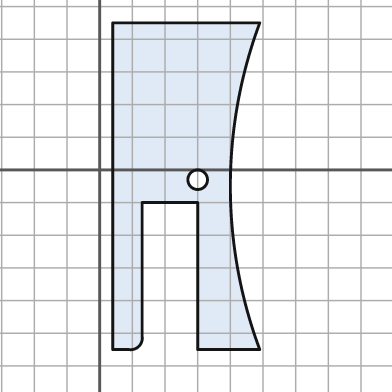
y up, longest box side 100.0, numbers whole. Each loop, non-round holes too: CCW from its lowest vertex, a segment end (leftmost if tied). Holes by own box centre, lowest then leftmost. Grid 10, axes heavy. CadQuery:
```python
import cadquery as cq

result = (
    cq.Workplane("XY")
    .moveTo(4.0, -55.0)
    .lineTo(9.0, -55.0)
    .threePointArc((12.0, -54.0), (13.0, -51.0))
    .lineTo(13.0, -10.0)
    .lineTo(30.0, -10.0)
    .lineTo(30.0, -55.0)
    .lineTo(49.0, -55.0)
    .threePointArc((40.0, -5.0), (49.0, 45.0))
    .lineTo(4.0, 45.0)
    .close()
    .moveTo(30.0, -3.0)
    .circle(3.0)
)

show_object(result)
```